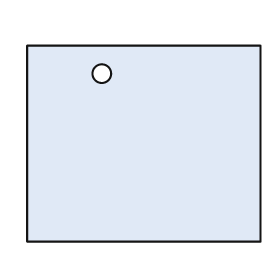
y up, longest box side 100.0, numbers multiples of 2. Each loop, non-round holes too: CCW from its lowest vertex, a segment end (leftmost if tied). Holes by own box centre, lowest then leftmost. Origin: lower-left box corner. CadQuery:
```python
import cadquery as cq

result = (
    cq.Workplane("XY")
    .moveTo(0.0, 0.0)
    .lineTo(100.0, 0.0)
    .lineTo(100.0, 84.0)
    .lineTo(0.0, 84.0)
    .close()
    .moveTo(32.0, 72.0)
    .circle(4.0)
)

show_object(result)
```